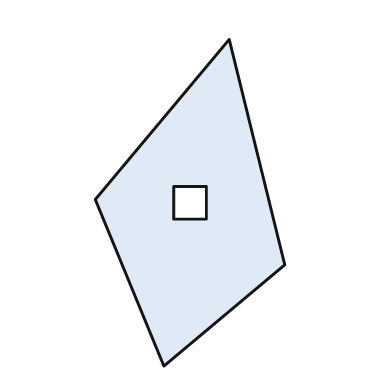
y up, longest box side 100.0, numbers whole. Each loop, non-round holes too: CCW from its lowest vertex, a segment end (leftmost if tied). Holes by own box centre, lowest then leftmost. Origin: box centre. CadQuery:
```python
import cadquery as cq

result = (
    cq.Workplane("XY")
    .moveTo(-8.0, -50.0)
    .lineTo(29.0, -19.0)
    .lineTo(12.0, 50.0)
    .lineTo(-29.0, 1.0)
    .close()
    .moveTo(-5.0, -5.0)
    .lineTo(5.0, -5.0)
    .lineTo(5.0, 5.0)
    .lineTo(-5.0, 5.0)
    .close()
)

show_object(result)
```